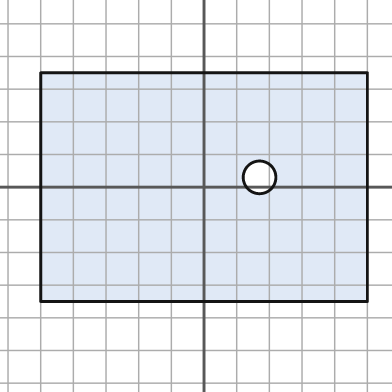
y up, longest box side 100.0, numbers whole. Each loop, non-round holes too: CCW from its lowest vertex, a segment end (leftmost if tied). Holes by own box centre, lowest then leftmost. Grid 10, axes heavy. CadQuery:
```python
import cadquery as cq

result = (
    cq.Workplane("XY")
    .moveTo(-50.0, -35.0)
    .lineTo(50.0, -35.0)
    .lineTo(50.0, 35.0)
    .lineTo(-50.0, 35.0)
    .close()
    .moveTo(17.0, 3.0)
    .circle(5.0)
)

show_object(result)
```